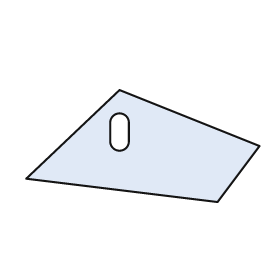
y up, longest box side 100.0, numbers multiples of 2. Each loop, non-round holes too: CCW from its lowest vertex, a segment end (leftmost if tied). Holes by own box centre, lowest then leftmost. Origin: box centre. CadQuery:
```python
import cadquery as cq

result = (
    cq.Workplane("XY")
    .moveTo(32.0, -24.0)
    .lineTo(50.0, 0.0)
    .lineTo(-10.0, 24.0)
    .lineTo(-50.0, -14.0)
    .close()
    .moveTo(-14.0, 2.0)
    .threePointArc((-10.0, -2.0), (-6.0, 2.0))
    .lineTo(-6.0, 10.0)
    .threePointArc((-10.0, 14.0), (-14.0, 10.0))
    .close()
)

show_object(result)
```